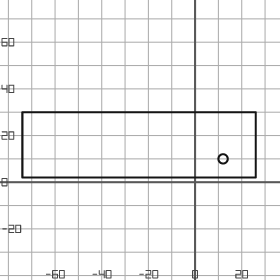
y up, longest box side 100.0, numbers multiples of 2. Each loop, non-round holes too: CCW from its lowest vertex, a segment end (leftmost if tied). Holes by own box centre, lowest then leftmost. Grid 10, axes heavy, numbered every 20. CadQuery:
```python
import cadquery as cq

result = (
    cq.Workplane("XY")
    .moveTo(-74.0, 2.0)
    .lineTo(26.0, 2.0)
    .lineTo(26.0, 30.0)
    .lineTo(-74.0, 30.0)
    .close()
    .moveTo(12.0, 10.0)
    .circle(2.0)
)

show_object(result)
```